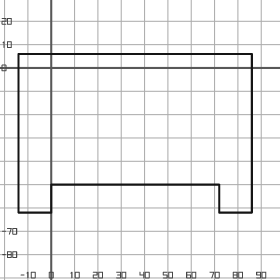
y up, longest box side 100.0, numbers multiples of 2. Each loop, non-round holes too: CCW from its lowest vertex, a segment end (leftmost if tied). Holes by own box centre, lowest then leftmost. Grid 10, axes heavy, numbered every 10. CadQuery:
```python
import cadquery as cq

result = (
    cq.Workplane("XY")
    .moveTo(-14.0, -62.0)
    .lineTo(0.0, -62.0)
    .lineTo(0.0, -50.0)
    .lineTo(72.0, -50.0)
    .lineTo(72.0, -62.0)
    .lineTo(86.0, -62.0)
    .lineTo(86.0, 6.0)
    .lineTo(-14.0, 6.0)
    .close()
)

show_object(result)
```